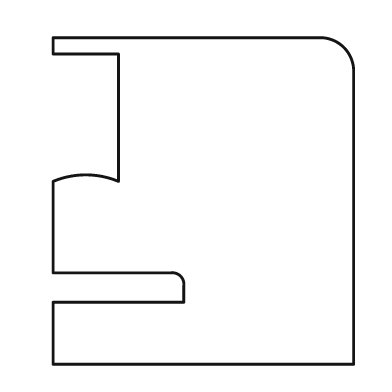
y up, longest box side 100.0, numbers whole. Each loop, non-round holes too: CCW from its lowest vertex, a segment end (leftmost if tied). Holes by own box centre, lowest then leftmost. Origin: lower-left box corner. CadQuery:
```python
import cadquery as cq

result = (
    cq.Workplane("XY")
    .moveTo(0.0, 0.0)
    .lineTo(92.0, 0.0)
    .lineTo(92.0, 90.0)
    .threePointArc((89.0, 97.0), (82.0, 100.0))
    .lineTo(0.0, 100.0)
    .lineTo(0.0, 95.0)
    .lineTo(20.0, 95.0)
    .lineTo(20.0, 56.0)
    .threePointArc((10.0, 58.0), (0.0, 56.0))
    .lineTo(0.0, 28.0)
    .lineTo(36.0, 28.0)
    .threePointArc((39.0, 27.0), (40.0, 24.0))
    .lineTo(40.0, 19.0)
    .lineTo(0.0, 19.0)
    .close()
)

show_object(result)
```